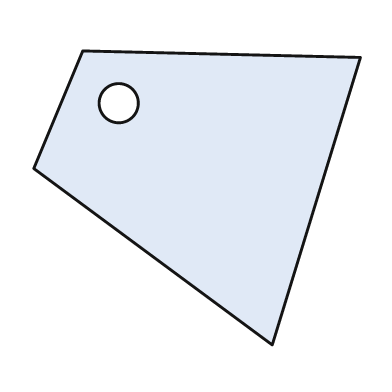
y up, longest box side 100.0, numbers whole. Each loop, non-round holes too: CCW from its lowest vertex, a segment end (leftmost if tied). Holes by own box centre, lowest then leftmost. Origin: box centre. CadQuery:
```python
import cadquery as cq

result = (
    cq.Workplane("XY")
    .moveTo(23.0, -45.0)
    .lineTo(50.0, 43.0)
    .lineTo(-35.0, 45.0)
    .lineTo(-50.0, 9.0)
    .close()
    .moveTo(-24.0, 29.0)
    .circle(6.0)
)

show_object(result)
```